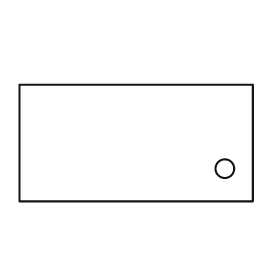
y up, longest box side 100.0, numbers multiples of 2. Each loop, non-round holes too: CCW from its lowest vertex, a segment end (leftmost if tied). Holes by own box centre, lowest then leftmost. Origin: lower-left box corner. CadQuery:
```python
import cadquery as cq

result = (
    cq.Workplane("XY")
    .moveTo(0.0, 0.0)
    .lineTo(100.0, 0.0)
    .lineTo(100.0, 50.0)
    .lineTo(0.0, 50.0)
    .close()
    .moveTo(88.0, 14.0)
    .circle(4.0)
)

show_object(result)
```